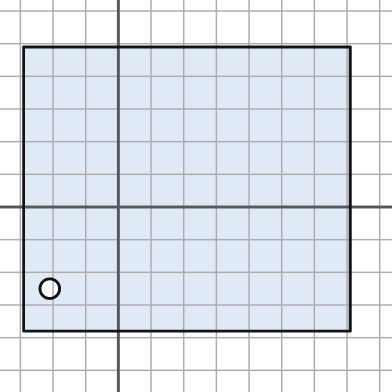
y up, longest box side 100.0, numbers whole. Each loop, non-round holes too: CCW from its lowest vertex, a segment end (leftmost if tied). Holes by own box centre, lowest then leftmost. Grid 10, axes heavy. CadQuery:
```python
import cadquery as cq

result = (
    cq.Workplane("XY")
    .moveTo(-29.0, -38.0)
    .lineTo(71.0, -38.0)
    .lineTo(71.0, 49.0)
    .lineTo(-29.0, 49.0)
    .close()
    .moveTo(-21.0, -25.0)
    .circle(3.0)
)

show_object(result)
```